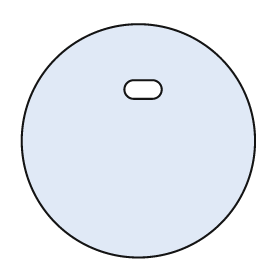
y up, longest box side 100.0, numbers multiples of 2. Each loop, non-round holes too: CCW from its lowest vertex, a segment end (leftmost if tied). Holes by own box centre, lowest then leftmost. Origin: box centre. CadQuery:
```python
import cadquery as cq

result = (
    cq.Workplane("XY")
    .moveTo(0.0, 0.0)
    .circle(50.0)
    .moveTo(-2.0, 18.0)
    .lineTo(6.0, 18.0)
    .threePointArc((10.0, 22.0), (6.0, 26.0))
    .lineTo(-2.0, 26.0)
    .threePointArc((-6.0, 22.0), (-2.0, 18.0))
    .close()
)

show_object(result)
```